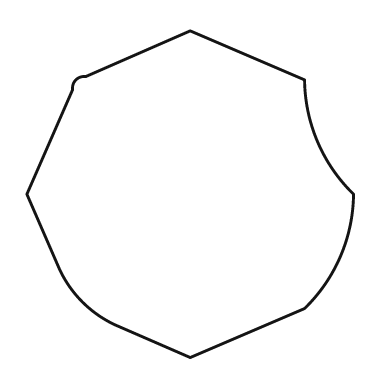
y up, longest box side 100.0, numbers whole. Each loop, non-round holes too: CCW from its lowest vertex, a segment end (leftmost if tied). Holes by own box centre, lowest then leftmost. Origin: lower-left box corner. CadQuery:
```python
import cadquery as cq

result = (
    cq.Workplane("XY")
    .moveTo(50.0, 0.0)
    .lineTo(85.0, 15.0)
    .threePointArc((96.0, 31.0), (100.0, 50.0))
    .threePointArc((89.0, 66.0), (85.0, 85.0))
    .lineTo(50.0, 100.0)
    .lineTo(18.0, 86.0)
    .threePointArc((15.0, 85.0), (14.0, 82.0))
    .lineTo(0.0, 50.0)
    .lineTo(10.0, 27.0)
    .threePointArc((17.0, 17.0), (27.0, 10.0))
    .close()
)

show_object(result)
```